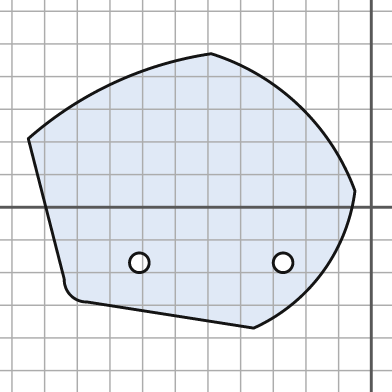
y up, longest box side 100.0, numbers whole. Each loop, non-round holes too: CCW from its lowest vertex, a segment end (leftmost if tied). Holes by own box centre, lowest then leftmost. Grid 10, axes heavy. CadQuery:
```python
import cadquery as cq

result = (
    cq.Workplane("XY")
    .moveTo(-36.0, -37.0)
    .threePointArc((-15.0, -20.0), (-5.0, 5.0))
    .threePointArc((-22.0, 31.0), (-49.0, 47.0))
    .threePointArc((-79.0, 38.0), (-105.0, 21.0))
    .lineTo(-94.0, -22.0)
    .threePointArc((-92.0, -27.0), (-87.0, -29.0))
    .close()
    .moveTo(-71.0, -17.0)
    .circle(3.0)
    .moveTo(-27.0, -17.0)
    .circle(3.0)
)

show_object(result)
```